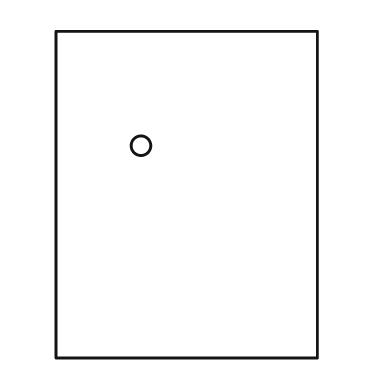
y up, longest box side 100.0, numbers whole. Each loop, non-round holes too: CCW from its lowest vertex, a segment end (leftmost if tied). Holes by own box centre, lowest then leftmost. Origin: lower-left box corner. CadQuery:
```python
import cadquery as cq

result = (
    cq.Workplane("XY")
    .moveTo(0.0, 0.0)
    .lineTo(80.0, 0.0)
    .lineTo(80.0, 100.0)
    .lineTo(0.0, 100.0)
    .close()
    .moveTo(26.0, 65.0)
    .circle(3.0)
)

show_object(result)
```